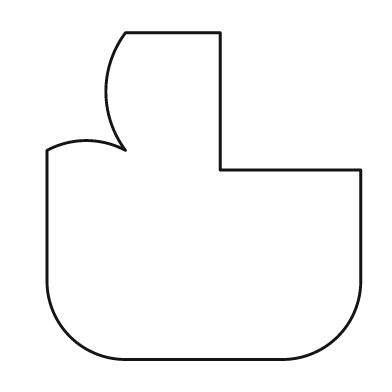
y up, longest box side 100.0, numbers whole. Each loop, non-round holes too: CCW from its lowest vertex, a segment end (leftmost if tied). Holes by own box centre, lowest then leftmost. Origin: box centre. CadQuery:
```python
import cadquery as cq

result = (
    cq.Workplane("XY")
    .moveTo(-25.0, -50.0)
    .lineTo(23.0, -50.0)
    .threePointArc((41.0, -43.0), (48.0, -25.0))
    .lineTo(48.0, 8.0)
    .lineTo(5.0, 8.0)
    .lineTo(5.0, 50.0)
    .lineTo(-24.0, 50.0)
    .threePointArc((-30.0, 32.0), (-24.0, 14.0))
    .threePointArc((-36.0, 17.0), (-48.0, 14.0))
    .lineTo(-48.0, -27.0)
    .threePointArc((-41.0, -43.0), (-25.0, -50.0))
    .close()
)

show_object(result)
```